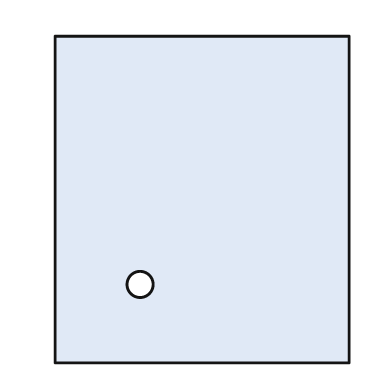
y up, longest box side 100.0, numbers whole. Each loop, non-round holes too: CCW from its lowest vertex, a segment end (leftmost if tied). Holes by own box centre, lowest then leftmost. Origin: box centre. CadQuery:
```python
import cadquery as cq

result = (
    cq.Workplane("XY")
    .moveTo(-45.0, -50.0)
    .lineTo(45.0, -50.0)
    .lineTo(45.0, 50.0)
    .lineTo(-45.0, 50.0)
    .close()
    .moveTo(-19.0, -26.0)
    .circle(4.0)
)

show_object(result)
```